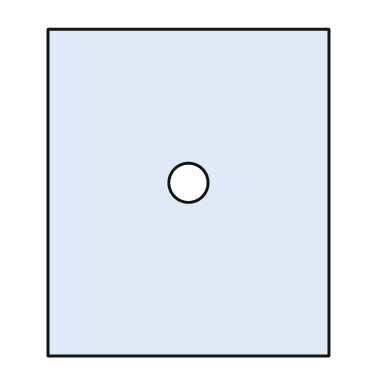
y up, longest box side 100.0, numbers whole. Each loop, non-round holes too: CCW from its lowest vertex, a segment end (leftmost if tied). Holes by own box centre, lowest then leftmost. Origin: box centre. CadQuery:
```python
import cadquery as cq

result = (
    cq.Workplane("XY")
    .moveTo(-43.0, -50.0)
    .lineTo(43.0, -50.0)
    .lineTo(43.0, 50.0)
    .lineTo(-43.0, 50.0)
    .close()
    .moveTo(0.0, 3.0)
    .circle(6.0)
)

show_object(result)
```